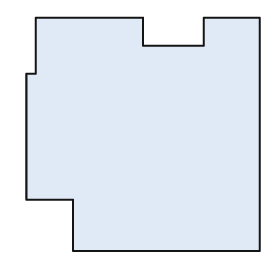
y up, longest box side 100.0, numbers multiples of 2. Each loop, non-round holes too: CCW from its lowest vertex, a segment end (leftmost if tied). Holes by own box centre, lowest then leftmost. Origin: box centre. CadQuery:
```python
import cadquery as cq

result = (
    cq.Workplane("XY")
    .moveTo(-30.0, -50.0)
    .lineTo(50.0, -50.0)
    .lineTo(50.0, 50.0)
    .lineTo(26.0, 50.0)
    .lineTo(26.0, 38.0)
    .lineTo(0.0, 38.0)
    .lineTo(0.0, 50.0)
    .lineTo(-46.0, 50.0)
    .lineTo(-46.0, 26.0)
    .lineTo(-50.0, 26.0)
    .lineTo(-50.0, -28.0)
    .lineTo(-30.0, -28.0)
    .close()
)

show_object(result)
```